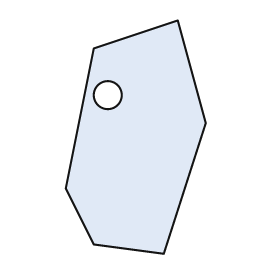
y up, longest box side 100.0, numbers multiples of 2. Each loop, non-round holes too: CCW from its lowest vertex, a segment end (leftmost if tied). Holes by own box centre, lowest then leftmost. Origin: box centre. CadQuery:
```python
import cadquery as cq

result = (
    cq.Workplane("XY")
    .moveTo(12.0, -50.0)
    .lineTo(30.0, 6.0)
    .lineTo(18.0, 50.0)
    .lineTo(-18.0, 38.0)
    .lineTo(-30.0, -22.0)
    .lineTo(-18.0, -46.0)
    .close()
    .moveTo(-12.0, 18.0)
    .circle(6.0)
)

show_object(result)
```